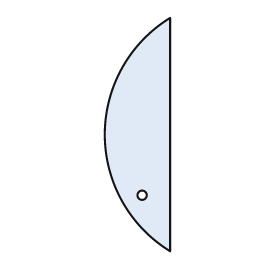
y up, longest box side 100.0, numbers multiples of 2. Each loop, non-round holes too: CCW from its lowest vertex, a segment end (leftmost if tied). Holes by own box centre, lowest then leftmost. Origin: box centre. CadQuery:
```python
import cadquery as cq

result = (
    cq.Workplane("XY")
    .moveTo(14.0, -50.0)
    .lineTo(14.0, 50.0)
    .threePointArc((-14.0, 0.0), (14.0, -50.0))
    .close()
    .moveTo(2.0, -26.0)
    .circle(2.0)
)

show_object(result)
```